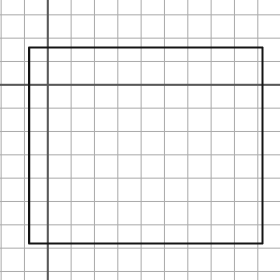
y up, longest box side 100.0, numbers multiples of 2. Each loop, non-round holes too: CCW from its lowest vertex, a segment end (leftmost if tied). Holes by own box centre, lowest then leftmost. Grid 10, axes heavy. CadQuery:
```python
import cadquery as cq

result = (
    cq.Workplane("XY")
    .moveTo(-8.0, -68.0)
    .lineTo(92.0, -68.0)
    .lineTo(92.0, 16.0)
    .lineTo(-8.0, 16.0)
    .close()
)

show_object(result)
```